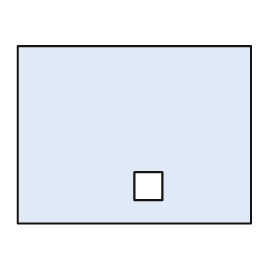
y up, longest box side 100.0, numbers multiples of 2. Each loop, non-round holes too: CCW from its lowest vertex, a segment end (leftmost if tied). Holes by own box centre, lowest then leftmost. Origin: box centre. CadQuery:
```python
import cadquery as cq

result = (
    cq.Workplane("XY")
    .moveTo(-50.0, -38.0)
    .lineTo(50.0, -38.0)
    .lineTo(50.0, 38.0)
    .lineTo(-50.0, 38.0)
    .close()
    .moveTo(0.0, -28.0)
    .lineTo(12.0, -28.0)
    .lineTo(12.0, -16.0)
    .lineTo(0.0, -16.0)
    .close()
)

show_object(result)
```